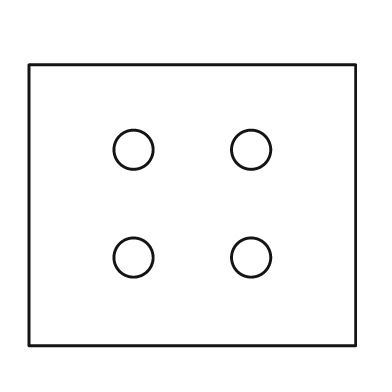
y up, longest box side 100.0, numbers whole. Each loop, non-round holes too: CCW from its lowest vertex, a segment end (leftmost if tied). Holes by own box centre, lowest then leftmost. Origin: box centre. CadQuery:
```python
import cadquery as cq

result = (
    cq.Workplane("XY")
    .moveTo(-50.0, -43.0)
    .lineTo(50.0, -43.0)
    .lineTo(50.0, 43.0)
    .lineTo(-50.0, 43.0)
    .close()
    .moveTo(-18.0, -16.0)
    .circle(6.0)
    .moveTo(18.0, -16.0)
    .circle(6.0)
    .moveTo(-18.0, 17.0)
    .circle(6.0)
    .moveTo(18.0, 17.0)
    .circle(6.0)
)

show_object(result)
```